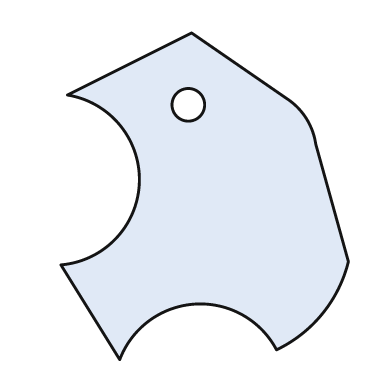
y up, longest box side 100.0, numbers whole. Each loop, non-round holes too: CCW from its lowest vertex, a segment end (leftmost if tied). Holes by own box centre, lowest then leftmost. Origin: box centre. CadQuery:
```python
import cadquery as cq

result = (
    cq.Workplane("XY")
    .moveTo(-26.0, -50.0)
    .threePointArc((-3.0, -33.0), (22.0, -47.0))
    .threePointArc((36.0, -36.0), (44.0, -20.0))
    .lineTo(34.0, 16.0)
    .threePointArc((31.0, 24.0), (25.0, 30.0))
    .lineTo(-4.0, 50.0)
    .lineTo(-42.0, 31.0)
    .threePointArc((-20.0, 4.0), (-44.0, -21.0))
    .close()
    .moveTo(-5.0, 28.0)
    .circle(5.0)
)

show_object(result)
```